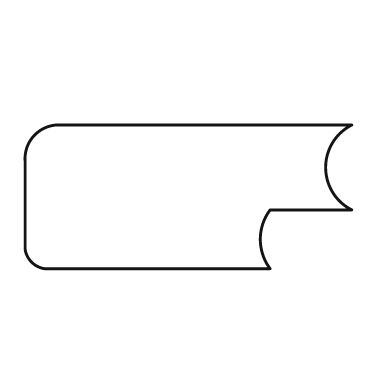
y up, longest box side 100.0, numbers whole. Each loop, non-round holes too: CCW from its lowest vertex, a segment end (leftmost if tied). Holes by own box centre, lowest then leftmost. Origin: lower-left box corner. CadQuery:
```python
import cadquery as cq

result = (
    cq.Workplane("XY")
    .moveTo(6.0, 0.0)
    .lineTo(75.0, 0.0)
    .threePointArc((72.0, 9.0), (75.0, 18.0))
    .lineTo(100.0, 18.0)
    .threePointArc((92.0, 31.0), (100.0, 44.0))
    .lineTo(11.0, 44.0)
    .threePointArc((3.0, 41.0), (0.0, 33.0))
    .lineTo(0.0, 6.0)
    .threePointArc((2.0, 2.0), (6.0, 0.0))
    .close()
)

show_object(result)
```